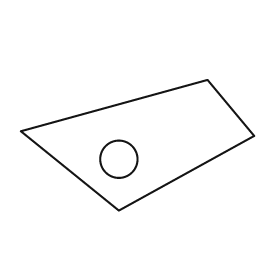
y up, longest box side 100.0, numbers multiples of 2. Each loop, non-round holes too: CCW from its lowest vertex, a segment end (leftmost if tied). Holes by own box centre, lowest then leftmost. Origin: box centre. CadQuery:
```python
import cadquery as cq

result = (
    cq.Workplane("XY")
    .moveTo(-8.0, -28.0)
    .lineTo(50.0, 4.0)
    .lineTo(30.0, 28.0)
    .lineTo(-50.0, 6.0)
    .close()
    .moveTo(-8.0, -6.0)
    .circle(8.0)
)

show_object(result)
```